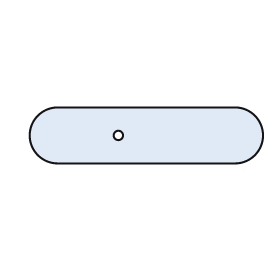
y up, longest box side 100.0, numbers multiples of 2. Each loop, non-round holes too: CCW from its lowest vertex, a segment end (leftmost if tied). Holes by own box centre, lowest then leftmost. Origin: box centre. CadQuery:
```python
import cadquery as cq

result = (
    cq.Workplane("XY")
    .moveTo(-38.0, -12.0)
    .lineTo(38.0, -12.0)
    .threePointArc((50.0, 0.0), (38.0, 12.0))
    .lineTo(-38.0, 12.0)
    .threePointArc((-50.0, 0.0), (-38.0, -12.0))
    .close()
    .moveTo(-12.0, 0.0)
    .circle(2.0)
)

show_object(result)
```